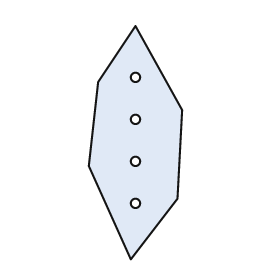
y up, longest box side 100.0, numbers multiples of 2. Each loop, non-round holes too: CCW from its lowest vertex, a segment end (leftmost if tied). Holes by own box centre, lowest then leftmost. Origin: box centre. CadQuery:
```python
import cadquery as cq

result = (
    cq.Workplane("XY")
    .moveTo(-2.0, -50.0)
    .lineTo(18.0, -24.0)
    .lineTo(20.0, 14.0)
    .lineTo(0.0, 50.0)
    .lineTo(-16.0, 26.0)
    .lineTo(-20.0, -10.0)
    .close()
    .moveTo(0.0, -26.0)
    .circle(2.0)
    .moveTo(0.0, -8.0)
    .circle(2.0)
    .moveTo(0.0, 10.0)
    .circle(2.0)
    .moveTo(0.0, 28.0)
    .circle(2.0)
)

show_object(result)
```